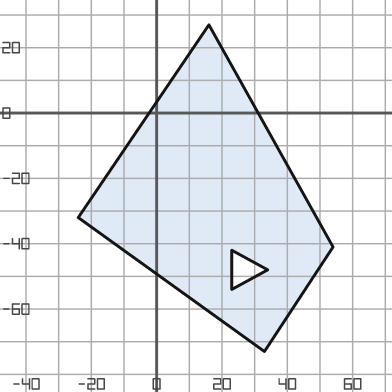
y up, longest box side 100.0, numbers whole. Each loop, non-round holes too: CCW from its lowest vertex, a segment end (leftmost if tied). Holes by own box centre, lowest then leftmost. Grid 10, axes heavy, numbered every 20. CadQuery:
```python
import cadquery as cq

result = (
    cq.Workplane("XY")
    .moveTo(33.0, -73.0)
    .lineTo(54.0, -41.0)
    .lineTo(16.0, 27.0)
    .lineTo(-24.0, -32.0)
    .close()
    .moveTo(23.0, -54.0)
    .lineTo(34.0, -48.0)
    .lineTo(23.0, -42.0)
    .close()
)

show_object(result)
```